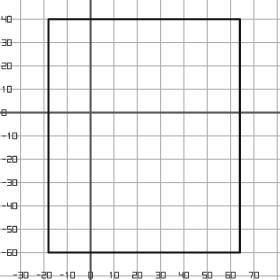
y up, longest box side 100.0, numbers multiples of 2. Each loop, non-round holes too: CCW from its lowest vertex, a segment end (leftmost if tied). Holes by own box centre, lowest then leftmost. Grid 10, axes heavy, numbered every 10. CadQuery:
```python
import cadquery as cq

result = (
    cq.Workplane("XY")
    .moveTo(-18.0, -60.0)
    .lineTo(64.0, -60.0)
    .lineTo(64.0, 40.0)
    .lineTo(-18.0, 40.0)
    .close()
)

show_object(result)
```